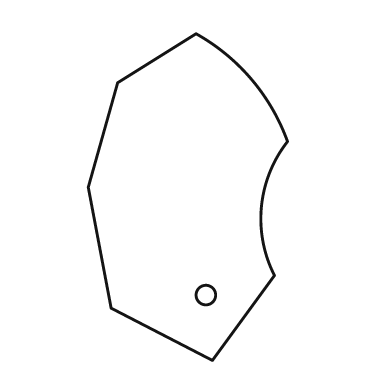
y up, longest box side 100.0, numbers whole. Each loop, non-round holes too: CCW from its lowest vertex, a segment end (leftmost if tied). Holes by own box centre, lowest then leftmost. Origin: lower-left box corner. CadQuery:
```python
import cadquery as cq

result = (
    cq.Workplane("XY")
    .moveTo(38.0, 0.0)
    .lineTo(57.0, 26.0)
    .threePointArc((53.0, 47.0), (61.0, 67.0))
    .threePointArc((50.0, 86.0), (33.0, 100.0))
    .lineTo(9.0, 85.0)
    .lineTo(0.0, 53.0)
    .lineTo(7.0, 16.0)
    .close()
    .moveTo(36.0, 20.0)
    .circle(3.0)
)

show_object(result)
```